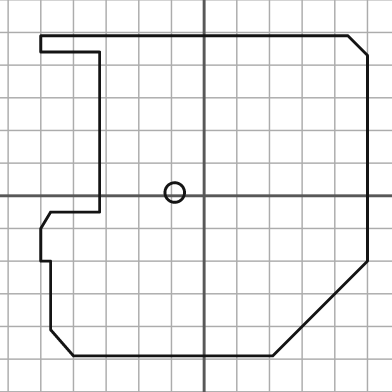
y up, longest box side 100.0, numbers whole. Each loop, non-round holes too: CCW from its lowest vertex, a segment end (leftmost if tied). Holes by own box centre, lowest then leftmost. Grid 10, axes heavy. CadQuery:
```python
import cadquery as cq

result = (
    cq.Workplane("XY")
    .moveTo(-40.0, -49.0)
    .lineTo(21.0, -49.0)
    .lineTo(50.0, -20.0)
    .lineTo(50.0, 43.0)
    .lineTo(44.0, 49.0)
    .lineTo(-50.0, 49.0)
    .lineTo(-50.0, 44.0)
    .lineTo(-32.0, 44.0)
    .lineTo(-32.0, -5.0)
    .lineTo(-47.0, -5.0)
    .lineTo(-50.0, -10.0)
    .lineTo(-50.0, -20.0)
    .lineTo(-47.0, -20.0)
    .lineTo(-47.0, -41.0)
    .close()
    .moveTo(-9.0, 1.0)
    .circle(3.0)
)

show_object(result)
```